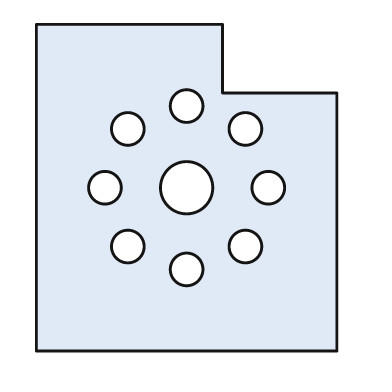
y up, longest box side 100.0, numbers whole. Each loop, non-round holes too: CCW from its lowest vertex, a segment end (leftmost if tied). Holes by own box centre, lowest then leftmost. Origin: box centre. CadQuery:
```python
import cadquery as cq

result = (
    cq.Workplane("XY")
    .moveTo(-46.0, -50.0)
    .lineTo(46.0, -50.0)
    .lineTo(46.0, 29.0)
    .lineTo(11.0, 29.0)
    .lineTo(11.0, 50.0)
    .lineTo(-46.0, 50.0)
    .close()
    .moveTo(0.0, -25.0)
    .circle(5.0)
    .moveTo(-18.0, -18.0)
    .circle(5.0)
    .moveTo(18.0, -18.0)
    .circle(5.0)
    .moveTo(-25.0, 0.0)
    .circle(5.0)
    .moveTo(0.0, 0.0)
    .circle(8.0)
    .moveTo(25.0, 0.0)
    .circle(5.0)
    .moveTo(-18.0, 18.0)
    .circle(5.0)
    .moveTo(18.0, 18.0)
    .circle(5.0)
    .moveTo(0.0, 25.0)
    .circle(5.0)
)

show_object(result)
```